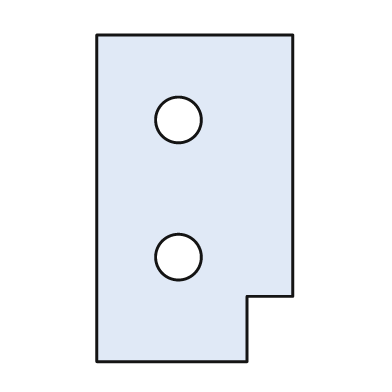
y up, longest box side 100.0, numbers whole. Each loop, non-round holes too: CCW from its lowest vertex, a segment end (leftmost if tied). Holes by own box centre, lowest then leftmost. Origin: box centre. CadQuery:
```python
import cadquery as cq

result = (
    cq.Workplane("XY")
    .moveTo(-30.0, -50.0)
    .lineTo(16.0, -50.0)
    .lineTo(16.0, -30.0)
    .lineTo(30.0, -30.0)
    .lineTo(30.0, 50.0)
    .lineTo(-30.0, 50.0)
    .close()
    .moveTo(-5.0, -18.0)
    .circle(7.0)
    .moveTo(-5.0, 24.0)
    .circle(7.0)
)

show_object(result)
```